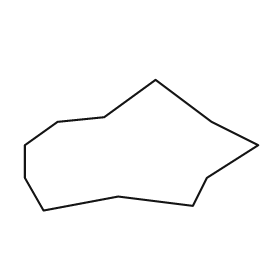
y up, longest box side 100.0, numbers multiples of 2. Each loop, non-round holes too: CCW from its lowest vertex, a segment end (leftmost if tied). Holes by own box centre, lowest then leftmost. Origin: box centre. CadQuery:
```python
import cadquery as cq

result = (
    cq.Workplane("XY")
    .moveTo(-42.0, -28.0)
    .lineTo(-10.0, -22.0)
    .lineTo(22.0, -26.0)
    .lineTo(28.0, -14.0)
    .lineTo(50.0, 0.0)
    .lineTo(30.0, 10.0)
    .lineTo(6.0, 28.0)
    .lineTo(-16.0, 12.0)
    .lineTo(-36.0, 10.0)
    .lineTo(-50.0, 0.0)
    .lineTo(-50.0, -14.0)
    .close()
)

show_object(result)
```